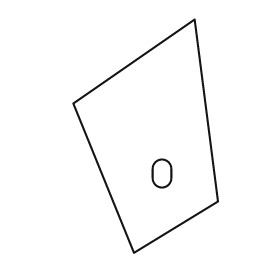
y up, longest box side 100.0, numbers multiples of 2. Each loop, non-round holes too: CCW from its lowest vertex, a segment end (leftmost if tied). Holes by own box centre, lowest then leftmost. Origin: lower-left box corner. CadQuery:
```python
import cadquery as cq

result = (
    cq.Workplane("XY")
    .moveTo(26.0, 0.0)
    .lineTo(62.0, 22.0)
    .lineTo(52.0, 100.0)
    .lineTo(0.0, 64.0)
    .close()
    .moveTo(34.0, 32.0)
    .threePointArc((38.0, 28.0), (42.0, 32.0))
    .lineTo(42.0, 36.0)
    .threePointArc((38.0, 40.0), (34.0, 36.0))
    .close()
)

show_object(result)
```